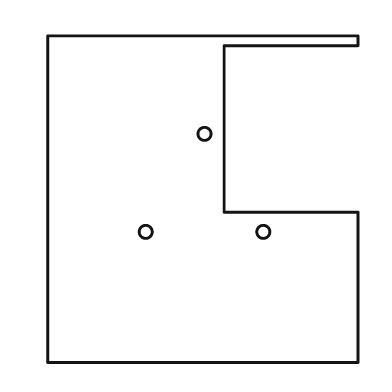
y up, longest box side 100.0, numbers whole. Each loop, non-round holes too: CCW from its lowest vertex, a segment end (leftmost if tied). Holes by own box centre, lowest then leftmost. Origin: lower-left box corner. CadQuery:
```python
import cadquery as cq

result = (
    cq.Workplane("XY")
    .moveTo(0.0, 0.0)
    .lineTo(95.0, 0.0)
    .lineTo(95.0, 46.0)
    .lineTo(54.0, 46.0)
    .lineTo(54.0, 97.0)
    .lineTo(95.0, 97.0)
    .lineTo(95.0, 100.0)
    .lineTo(0.0, 100.0)
    .close()
    .moveTo(30.0, 40.0)
    .circle(2.0)
    .moveTo(66.0, 40.0)
    .circle(2.0)
    .moveTo(48.0, 70.0)
    .circle(2.0)
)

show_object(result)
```